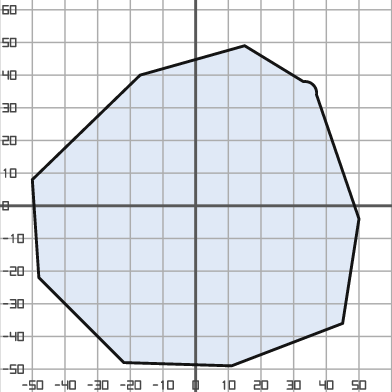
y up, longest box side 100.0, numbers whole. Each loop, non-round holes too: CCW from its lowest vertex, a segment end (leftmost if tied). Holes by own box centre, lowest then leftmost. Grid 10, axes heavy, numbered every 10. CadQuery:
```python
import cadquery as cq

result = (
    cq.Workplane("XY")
    .moveTo(11.0, -49.0)
    .lineTo(45.0, -36.0)
    .lineTo(50.0, -4.0)
    .lineTo(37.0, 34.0)
    .threePointArc((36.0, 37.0), (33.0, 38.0))
    .lineTo(15.0, 49.0)
    .lineTo(-17.0, 40.0)
    .lineTo(-50.0, 8.0)
    .lineTo(-48.0, -22.0)
    .lineTo(-22.0, -48.0)
    .close()
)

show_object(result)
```